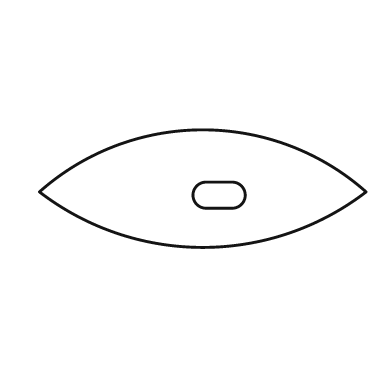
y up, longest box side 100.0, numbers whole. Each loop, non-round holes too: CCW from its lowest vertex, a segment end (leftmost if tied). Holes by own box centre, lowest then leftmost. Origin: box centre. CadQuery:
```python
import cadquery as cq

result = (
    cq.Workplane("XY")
    .moveTo(-50.0, -1.0)
    .threePointArc((0.0, -18.0), (50.0, -1.0))
    .threePointArc((0.0, 18.0), (-50.0, -1.0))
    .close()
    .moveTo(1.0, -6.0)
    .lineTo(9.0, -6.0)
    .threePointArc((13.0, -2.0), (9.0, 2.0))
    .lineTo(1.0, 2.0)
    .threePointArc((-3.0, -2.0), (1.0, -6.0))
    .close()
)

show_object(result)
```